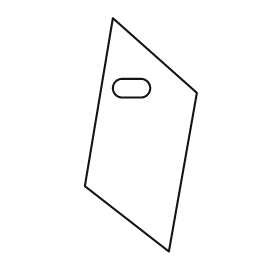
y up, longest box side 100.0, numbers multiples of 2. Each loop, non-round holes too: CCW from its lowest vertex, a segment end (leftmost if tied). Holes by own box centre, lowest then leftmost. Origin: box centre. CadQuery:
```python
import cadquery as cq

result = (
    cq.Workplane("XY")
    .moveTo(12.0, -50.0)
    .lineTo(24.0, 18.0)
    .lineTo(-12.0, 50.0)
    .lineTo(-24.0, -22.0)
    .close()
    .moveTo(-8.0, 16.0)
    .lineTo(0.0, 16.0)
    .threePointArc((4.0, 20.0), (0.0, 24.0))
    .lineTo(-8.0, 24.0)
    .threePointArc((-12.0, 20.0), (-8.0, 16.0))
    .close()
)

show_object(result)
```